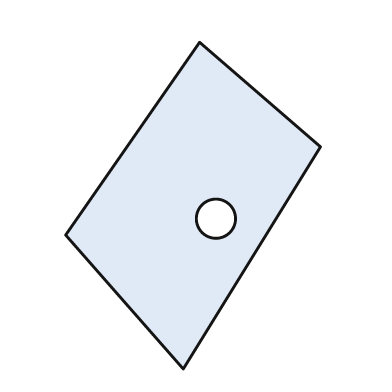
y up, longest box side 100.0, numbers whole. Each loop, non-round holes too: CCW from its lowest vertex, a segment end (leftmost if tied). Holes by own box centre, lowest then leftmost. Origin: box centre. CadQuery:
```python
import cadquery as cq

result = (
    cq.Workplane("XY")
    .moveTo(-3.0, -50.0)
    .lineTo(39.0, 18.0)
    .lineTo(2.0, 50.0)
    .lineTo(-39.0, -9.0)
    .close()
    .moveTo(7.0, -4.0)
    .circle(6.0)
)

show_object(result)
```